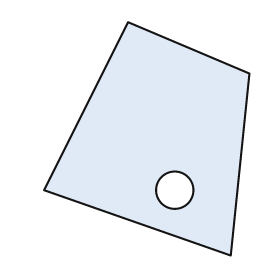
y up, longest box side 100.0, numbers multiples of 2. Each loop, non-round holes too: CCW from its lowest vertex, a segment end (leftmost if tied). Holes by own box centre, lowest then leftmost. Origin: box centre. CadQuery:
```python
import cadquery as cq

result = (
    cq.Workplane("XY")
    .moveTo(36.0, -50.0)
    .lineTo(44.0, 28.0)
    .lineTo(-8.0, 50.0)
    .lineTo(-44.0, -22.0)
    .close()
    .moveTo(12.0, -22.0)
    .circle(8.0)
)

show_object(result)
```